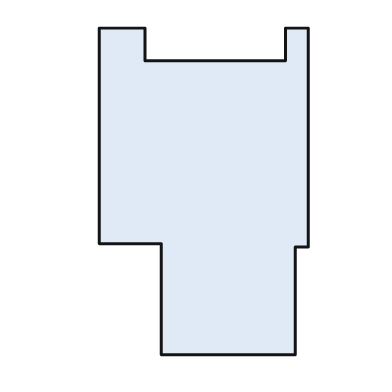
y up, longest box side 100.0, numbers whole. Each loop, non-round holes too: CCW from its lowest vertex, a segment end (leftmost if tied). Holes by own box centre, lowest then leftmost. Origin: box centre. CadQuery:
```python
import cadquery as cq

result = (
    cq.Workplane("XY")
    .moveTo(-13.0, -50.0)
    .lineTo(28.0, -50.0)
    .lineTo(28.0, -17.0)
    .lineTo(32.0, -17.0)
    .lineTo(32.0, 50.0)
    .lineTo(25.0, 50.0)
    .lineTo(25.0, 40.0)
    .lineTo(-18.0, 40.0)
    .lineTo(-18.0, 50.0)
    .lineTo(-32.0, 50.0)
    .lineTo(-32.0, -16.0)
    .lineTo(-13.0, -16.0)
    .close()
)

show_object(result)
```